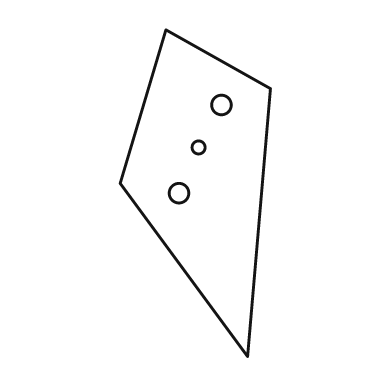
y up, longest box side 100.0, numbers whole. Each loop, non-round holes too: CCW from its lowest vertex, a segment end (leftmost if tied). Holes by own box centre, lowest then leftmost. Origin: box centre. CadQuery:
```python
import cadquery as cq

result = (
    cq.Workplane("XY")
    .moveTo(16.0, -50.0)
    .lineTo(23.0, 32.0)
    .lineTo(-9.0, 50.0)
    .lineTo(-23.0, 3.0)
    .close()
    .moveTo(-5.0, 0.0)
    .circle(3.0)
    .moveTo(1.0, 14.0)
    .circle(2.0)
    .moveTo(8.0, 27.0)
    .circle(3.0)
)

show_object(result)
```